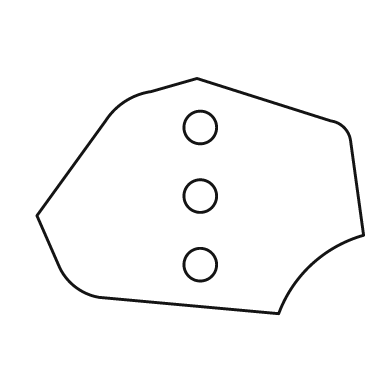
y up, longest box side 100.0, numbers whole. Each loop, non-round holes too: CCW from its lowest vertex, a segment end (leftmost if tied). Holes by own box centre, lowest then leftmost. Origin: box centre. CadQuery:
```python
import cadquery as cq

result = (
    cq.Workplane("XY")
    .moveTo(24.0, -36.0)
    .threePointArc((34.0, -21.0), (50.0, -12.0))
    .lineTo(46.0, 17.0)
    .threePointArc((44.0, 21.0), (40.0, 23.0))
    .lineTo(-1.0, 36.0)
    .lineTo(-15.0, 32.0)
    .threePointArc((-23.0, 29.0), (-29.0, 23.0))
    .lineTo(-50.0, -6.0)
    .lineTo(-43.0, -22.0)
    .threePointArc((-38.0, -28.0), (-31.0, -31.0))
    .close()
    .moveTo(0.0, -21.0)
    .circle(5.0)
    .moveTo(0.0, 0.0)
    .circle(5.0)
    .moveTo(0.0, 21.0)
    .circle(5.0)
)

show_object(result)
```